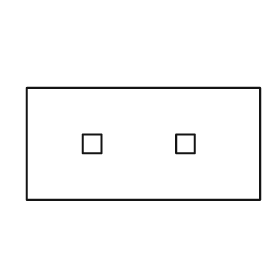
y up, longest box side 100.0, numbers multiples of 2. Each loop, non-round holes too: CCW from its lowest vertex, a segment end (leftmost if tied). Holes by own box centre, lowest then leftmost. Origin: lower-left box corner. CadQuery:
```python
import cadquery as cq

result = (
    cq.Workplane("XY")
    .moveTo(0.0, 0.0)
    .lineTo(100.0, 0.0)
    .lineTo(100.0, 48.0)
    .lineTo(0.0, 48.0)
    .close()
    .moveTo(24.0, 20.0)
    .lineTo(32.0, 20.0)
    .lineTo(32.0, 28.0)
    .lineTo(24.0, 28.0)
    .close()
    .moveTo(64.0, 20.0)
    .lineTo(72.0, 20.0)
    .lineTo(72.0, 28.0)
    .lineTo(64.0, 28.0)
    .close()
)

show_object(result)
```